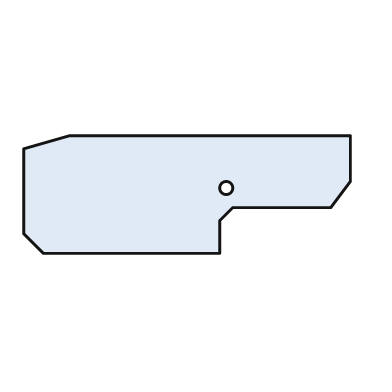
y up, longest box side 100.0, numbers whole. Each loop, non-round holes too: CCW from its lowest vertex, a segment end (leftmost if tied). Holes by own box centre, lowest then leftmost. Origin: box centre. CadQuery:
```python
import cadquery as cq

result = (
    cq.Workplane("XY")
    .moveTo(-44.0, -18.0)
    .lineTo(10.0, -18.0)
    .lineTo(10.0, -8.0)
    .lineTo(14.0, -4.0)
    .lineTo(44.0, -4.0)
    .lineTo(50.0, 4.0)
    .lineTo(50.0, 18.0)
    .lineTo(-36.0, 18.0)
    .lineTo(-50.0, 14.0)
    .lineTo(-50.0, -12.0)
    .close()
    .moveTo(12.0, 2.0)
    .circle(2.0)
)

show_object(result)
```